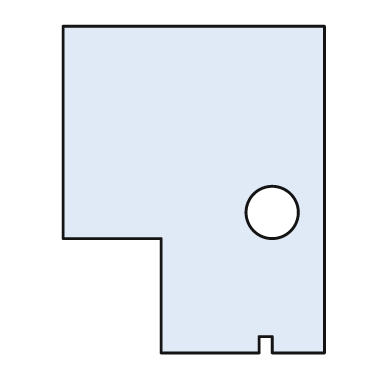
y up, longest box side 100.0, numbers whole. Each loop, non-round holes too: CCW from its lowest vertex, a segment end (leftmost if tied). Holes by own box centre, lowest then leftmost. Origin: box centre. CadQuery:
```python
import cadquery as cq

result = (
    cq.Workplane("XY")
    .moveTo(-10.0, -50.0)
    .lineTo(20.0, -50.0)
    .lineTo(20.0, -45.0)
    .lineTo(24.0, -45.0)
    .lineTo(24.0, -50.0)
    .lineTo(40.0, -50.0)
    .lineTo(40.0, 50.0)
    .lineTo(-40.0, 50.0)
    .lineTo(-40.0, -15.0)
    .lineTo(-10.0, -15.0)
    .close()
    .moveTo(24.0, -7.0)
    .circle(8.0)
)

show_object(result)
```